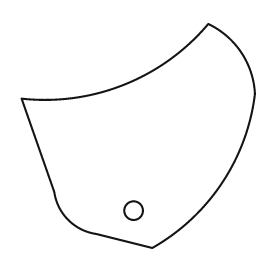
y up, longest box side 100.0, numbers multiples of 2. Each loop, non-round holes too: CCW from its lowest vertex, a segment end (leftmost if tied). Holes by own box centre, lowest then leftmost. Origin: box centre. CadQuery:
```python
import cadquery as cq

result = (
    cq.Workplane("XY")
    .moveTo(6.0, -48.0)
    .threePointArc((36.0, -20.0), (50.0, 18.0))
    .threePointArc((44.0, 36.0), (30.0, 48.0))
    .threePointArc((-6.0, 22.0), (-50.0, 16.0))
    .lineTo(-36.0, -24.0)
    .threePointArc((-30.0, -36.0), (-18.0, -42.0))
    .close()
    .moveTo(-2.0, -32.0)
    .circle(4.0)
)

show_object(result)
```